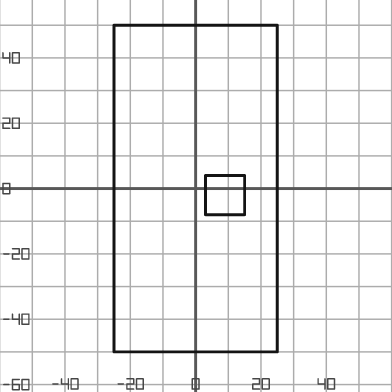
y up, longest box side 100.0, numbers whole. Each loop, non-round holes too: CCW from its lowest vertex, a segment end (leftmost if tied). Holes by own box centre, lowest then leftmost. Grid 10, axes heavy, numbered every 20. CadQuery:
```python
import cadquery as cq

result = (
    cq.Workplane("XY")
    .moveTo(-25.0, -50.0)
    .lineTo(25.0, -50.0)
    .lineTo(25.0, 50.0)
    .lineTo(-25.0, 50.0)
    .close()
    .moveTo(3.0, -8.0)
    .lineTo(15.0, -8.0)
    .lineTo(15.0, 4.0)
    .lineTo(3.0, 4.0)
    .close()
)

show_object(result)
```